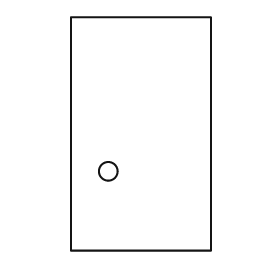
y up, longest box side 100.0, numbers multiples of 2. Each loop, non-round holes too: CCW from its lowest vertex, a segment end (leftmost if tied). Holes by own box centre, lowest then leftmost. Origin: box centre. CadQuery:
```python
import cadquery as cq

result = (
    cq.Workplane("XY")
    .moveTo(-30.0, -50.0)
    .lineTo(30.0, -50.0)
    .lineTo(30.0, 50.0)
    .lineTo(-30.0, 50.0)
    .close()
    .moveTo(-14.0, -16.0)
    .circle(4.0)
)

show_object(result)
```